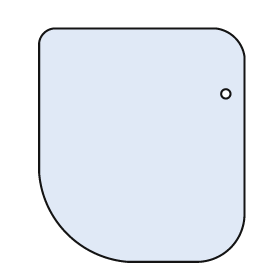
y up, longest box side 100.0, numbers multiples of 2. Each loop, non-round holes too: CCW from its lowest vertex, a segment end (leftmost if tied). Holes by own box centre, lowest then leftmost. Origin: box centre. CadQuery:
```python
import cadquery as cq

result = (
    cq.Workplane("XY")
    .moveTo(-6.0, -50.0)
    .lineTo(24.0, -50.0)
    .threePointArc((38.0, -44.0), (44.0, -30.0))
    .lineTo(44.0, 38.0)
    .threePointArc((40.0, 46.0), (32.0, 50.0))
    .lineTo(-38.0, 50.0)
    .threePointArc((-42.0, 48.0), (-44.0, 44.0))
    .lineTo(-44.0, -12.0)
    .threePointArc((-32.0, -38.0), (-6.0, -50.0))
    .close()
    .moveTo(36.0, 22.0)
    .circle(2.0)
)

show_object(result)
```